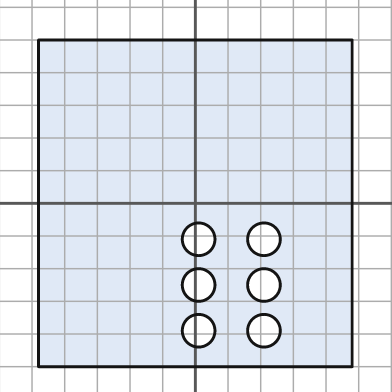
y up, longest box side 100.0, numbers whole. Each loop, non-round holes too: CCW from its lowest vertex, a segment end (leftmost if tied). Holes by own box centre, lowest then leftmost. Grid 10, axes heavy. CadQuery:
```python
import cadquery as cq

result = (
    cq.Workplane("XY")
    .moveTo(-48.0, -50.0)
    .lineTo(48.0, -50.0)
    .lineTo(48.0, 50.0)
    .lineTo(-48.0, 50.0)
    .close()
    .moveTo(1.0, -39.0)
    .circle(5.0)
    .moveTo(21.0, -39.0)
    .circle(5.0)
    .moveTo(1.0, -25.0)
    .circle(5.0)
    .moveTo(21.0, -25.0)
    .circle(5.0)
    .moveTo(1.0, -11.0)
    .circle(5.0)
    .moveTo(21.0, -11.0)
    .circle(5.0)
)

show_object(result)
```